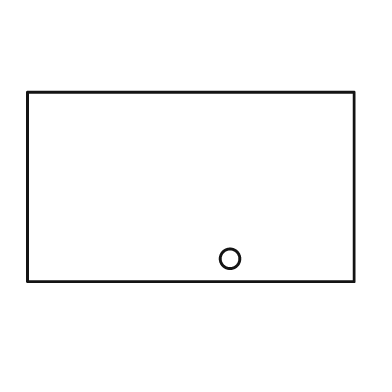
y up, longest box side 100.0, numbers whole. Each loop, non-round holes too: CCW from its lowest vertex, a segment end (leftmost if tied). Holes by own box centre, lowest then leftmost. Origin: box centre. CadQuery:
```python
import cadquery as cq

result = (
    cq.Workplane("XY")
    .moveTo(-50.0, -29.0)
    .lineTo(50.0, -29.0)
    .lineTo(50.0, 29.0)
    .lineTo(-50.0, 29.0)
    .close()
    .moveTo(12.0, -22.0)
    .circle(3.0)
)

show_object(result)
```